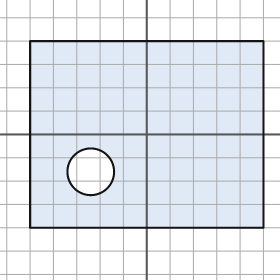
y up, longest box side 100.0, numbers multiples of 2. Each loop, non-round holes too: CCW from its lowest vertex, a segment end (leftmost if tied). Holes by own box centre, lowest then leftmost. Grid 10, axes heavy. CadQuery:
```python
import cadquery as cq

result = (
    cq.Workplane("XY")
    .moveTo(-50.0, -40.0)
    .lineTo(50.0, -40.0)
    .lineTo(50.0, 40.0)
    .lineTo(-50.0, 40.0)
    .close()
    .moveTo(-24.0, -16.0)
    .circle(10.0)
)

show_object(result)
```